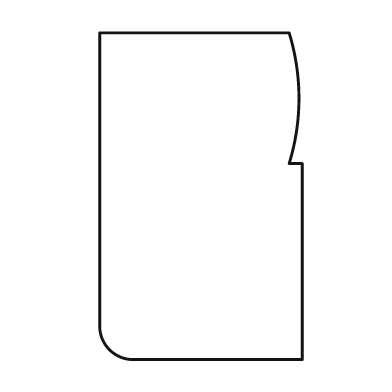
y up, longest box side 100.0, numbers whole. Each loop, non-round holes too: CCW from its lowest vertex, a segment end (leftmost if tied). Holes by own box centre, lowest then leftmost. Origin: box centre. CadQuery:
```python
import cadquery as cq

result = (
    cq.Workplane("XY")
    .moveTo(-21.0, -50.0)
    .lineTo(31.0, -50.0)
    .lineTo(31.0, 10.0)
    .lineTo(27.0, 10.0)
    .threePointArc((30.0, 30.0), (27.0, 50.0))
    .lineTo(-31.0, 50.0)
    .lineTo(-31.0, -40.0)
    .threePointArc((-28.0, -47.0), (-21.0, -50.0))
    .close()
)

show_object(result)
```